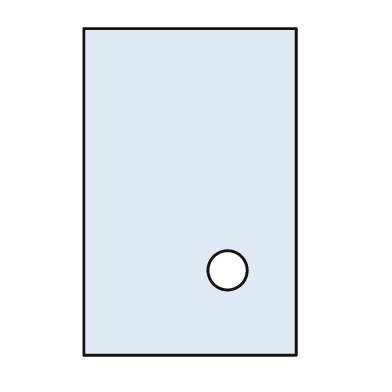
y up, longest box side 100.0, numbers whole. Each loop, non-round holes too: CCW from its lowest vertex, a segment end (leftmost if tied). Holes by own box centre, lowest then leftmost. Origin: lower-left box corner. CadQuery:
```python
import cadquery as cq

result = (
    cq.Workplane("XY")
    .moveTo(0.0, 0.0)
    .lineTo(65.0, 0.0)
    .lineTo(65.0, 100.0)
    .lineTo(0.0, 100.0)
    .close()
    .moveTo(44.0, 26.0)
    .circle(6.0)
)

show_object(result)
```